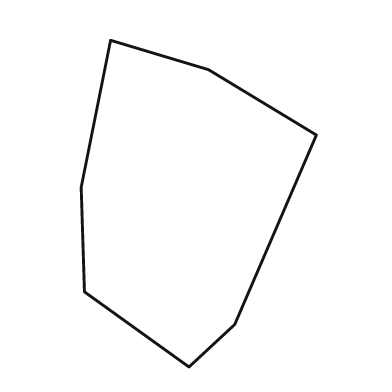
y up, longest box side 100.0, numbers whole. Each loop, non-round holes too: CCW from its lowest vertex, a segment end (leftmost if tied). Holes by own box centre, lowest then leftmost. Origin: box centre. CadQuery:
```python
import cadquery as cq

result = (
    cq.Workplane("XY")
    .moveTo(-3.0, -50.0)
    .lineTo(11.0, -37.0)
    .lineTo(36.0, 21.0)
    .lineTo(3.0, 41.0)
    .lineTo(-27.0, 50.0)
    .lineTo(-36.0, 5.0)
    .lineTo(-35.0, -27.0)
    .close()
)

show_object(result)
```